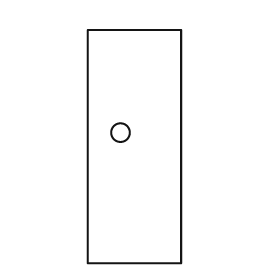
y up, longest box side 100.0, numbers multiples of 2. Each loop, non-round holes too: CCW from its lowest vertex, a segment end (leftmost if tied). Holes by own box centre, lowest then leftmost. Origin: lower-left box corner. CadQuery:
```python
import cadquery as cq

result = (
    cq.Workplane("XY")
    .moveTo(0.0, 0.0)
    .lineTo(40.0, 0.0)
    .lineTo(40.0, 100.0)
    .lineTo(0.0, 100.0)
    .close()
    .moveTo(14.0, 56.0)
    .circle(4.0)
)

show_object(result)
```